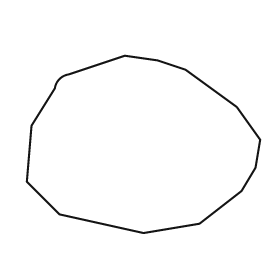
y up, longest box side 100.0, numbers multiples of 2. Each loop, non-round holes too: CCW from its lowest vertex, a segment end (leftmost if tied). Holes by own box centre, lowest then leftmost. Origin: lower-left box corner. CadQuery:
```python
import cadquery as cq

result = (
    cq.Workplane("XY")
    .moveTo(50.0, 0.0)
    .lineTo(74.0, 4.0)
    .lineTo(92.0, 18.0)
    .lineTo(98.0, 28.0)
    .lineTo(100.0, 40.0)
    .lineTo(90.0, 54.0)
    .lineTo(68.0, 70.0)
    .lineTo(56.0, 74.0)
    .lineTo(42.0, 76.0)
    .lineTo(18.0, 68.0)
    .threePointArc((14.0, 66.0), (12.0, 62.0))
    .lineTo(2.0, 46.0)
    .lineTo(0.0, 22.0)
    .lineTo(14.0, 8.0)
    .close()
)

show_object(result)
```